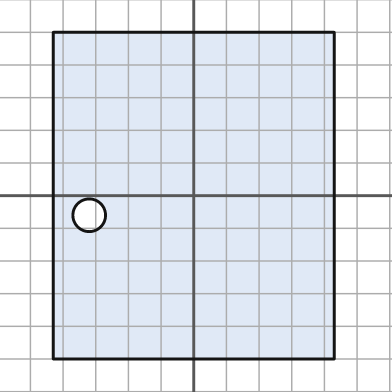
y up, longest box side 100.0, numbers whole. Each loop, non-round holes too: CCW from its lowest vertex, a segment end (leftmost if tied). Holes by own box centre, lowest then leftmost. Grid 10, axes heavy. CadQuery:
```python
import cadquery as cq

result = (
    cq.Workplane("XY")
    .moveTo(-43.0, -50.0)
    .lineTo(43.0, -50.0)
    .lineTo(43.0, 50.0)
    .lineTo(-43.0, 50.0)
    .close()
    .moveTo(-32.0, -6.0)
    .circle(5.0)
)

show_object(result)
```